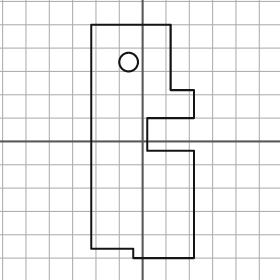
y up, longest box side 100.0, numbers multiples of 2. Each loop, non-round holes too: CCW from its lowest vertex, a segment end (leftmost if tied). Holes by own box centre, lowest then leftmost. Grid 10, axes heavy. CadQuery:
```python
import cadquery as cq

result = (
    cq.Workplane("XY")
    .moveTo(-4.0, -50.0)
    .lineTo(22.0, -50.0)
    .lineTo(22.0, -4.0)
    .lineTo(2.0, -4.0)
    .lineTo(2.0, 10.0)
    .lineTo(22.0, 10.0)
    .lineTo(22.0, 22.0)
    .lineTo(12.0, 22.0)
    .lineTo(12.0, 50.0)
    .lineTo(-22.0, 50.0)
    .lineTo(-22.0, -46.0)
    .lineTo(-4.0, -46.0)
    .close()
    .moveTo(-6.0, 34.0)
    .circle(4.0)
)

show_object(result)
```